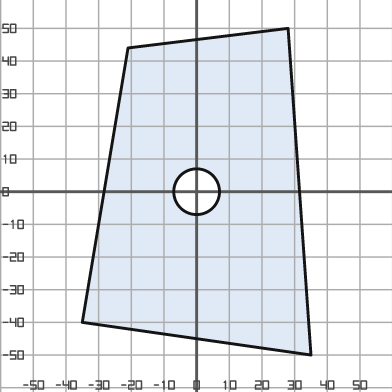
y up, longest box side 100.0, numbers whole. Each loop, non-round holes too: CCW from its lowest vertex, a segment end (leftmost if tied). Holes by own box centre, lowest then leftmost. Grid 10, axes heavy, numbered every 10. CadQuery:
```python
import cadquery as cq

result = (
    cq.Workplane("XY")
    .moveTo(35.0, -50.0)
    .lineTo(28.0, 50.0)
    .lineTo(-21.0, 44.0)
    .lineTo(-35.0, -40.0)
    .close()
    .moveTo(0.0, 0.0)
    .circle(7.0)
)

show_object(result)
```